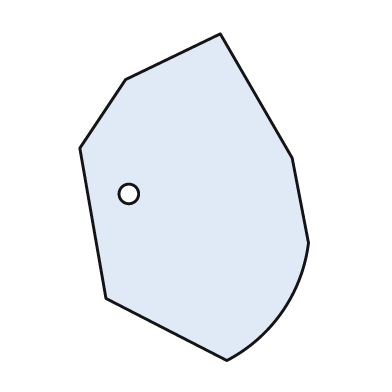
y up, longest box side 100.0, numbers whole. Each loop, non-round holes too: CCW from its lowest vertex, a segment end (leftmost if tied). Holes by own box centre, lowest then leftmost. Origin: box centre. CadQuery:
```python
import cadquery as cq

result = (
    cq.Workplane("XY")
    .moveTo(10.0, -50.0)
    .threePointArc((27.0, -35.0), (35.0, -14.0))
    .lineTo(30.0, 12.0)
    .lineTo(8.0, 50.0)
    .lineTo(-21.0, 36.0)
    .lineTo(-35.0, 15.0)
    .lineTo(-27.0, -31.0)
    .close()
    .moveTo(-20.0, 1.0)
    .circle(3.0)
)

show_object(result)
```